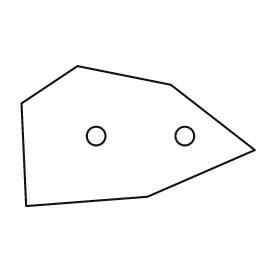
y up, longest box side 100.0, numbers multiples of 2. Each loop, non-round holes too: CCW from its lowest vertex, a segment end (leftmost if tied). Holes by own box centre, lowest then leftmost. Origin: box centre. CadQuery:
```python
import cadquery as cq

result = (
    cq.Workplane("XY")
    .moveTo(-48.0, -30.0)
    .lineTo(4.0, -26.0)
    .lineTo(50.0, -6.0)
    .lineTo(14.0, 22.0)
    .lineTo(-26.0, 30.0)
    .lineTo(-50.0, 14.0)
    .close()
    .moveTo(-18.0, 0.0)
    .circle(4.0)
    .moveTo(20.0, 0.0)
    .circle(4.0)
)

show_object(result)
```